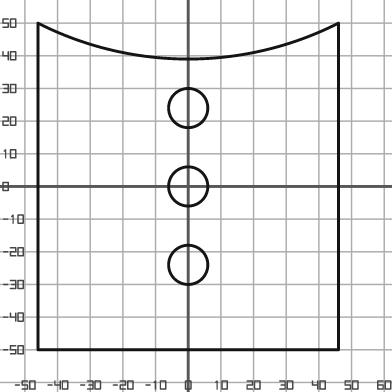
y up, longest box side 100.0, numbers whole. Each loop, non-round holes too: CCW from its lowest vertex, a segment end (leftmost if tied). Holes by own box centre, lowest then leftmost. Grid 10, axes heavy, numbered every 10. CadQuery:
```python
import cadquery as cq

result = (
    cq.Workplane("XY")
    .moveTo(-46.0, -50.0)
    .lineTo(46.0, -50.0)
    .lineTo(46.0, 50.0)
    .threePointArc((0.0, 39.0), (-46.0, 50.0))
    .close()
    .moveTo(0.0, -24.0)
    .circle(6.0)
    .moveTo(0.0, 0.0)
    .circle(6.0)
    .moveTo(0.0, 24.0)
    .circle(6.0)
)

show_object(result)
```